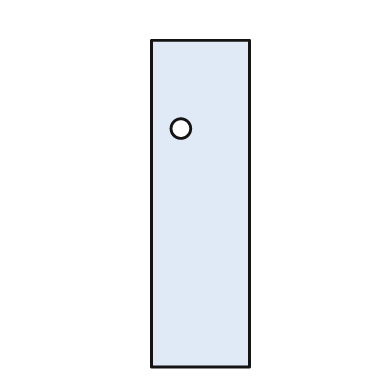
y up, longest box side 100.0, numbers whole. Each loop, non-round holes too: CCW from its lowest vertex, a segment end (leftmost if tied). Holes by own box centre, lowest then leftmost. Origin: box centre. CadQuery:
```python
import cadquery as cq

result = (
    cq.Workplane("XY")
    .moveTo(-15.0, -50.0)
    .lineTo(15.0, -50.0)
    .lineTo(15.0, 50.0)
    .lineTo(-15.0, 50.0)
    .close()
    .moveTo(-6.0, 23.0)
    .circle(3.0)
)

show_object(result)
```